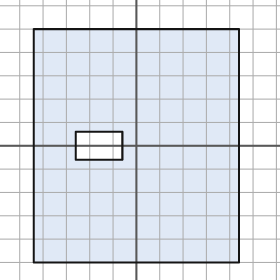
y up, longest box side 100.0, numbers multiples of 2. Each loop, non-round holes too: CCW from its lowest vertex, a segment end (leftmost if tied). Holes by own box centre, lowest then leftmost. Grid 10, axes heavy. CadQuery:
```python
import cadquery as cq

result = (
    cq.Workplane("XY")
    .moveTo(-44.0, -50.0)
    .lineTo(44.0, -50.0)
    .lineTo(44.0, 50.0)
    .lineTo(-44.0, 50.0)
    .close()
    .moveTo(-26.0, -6.0)
    .lineTo(-6.0, -6.0)
    .lineTo(-6.0, 6.0)
    .lineTo(-26.0, 6.0)
    .close()
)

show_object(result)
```